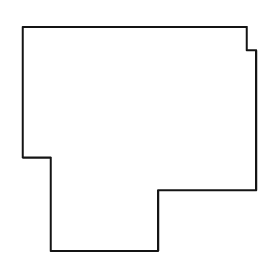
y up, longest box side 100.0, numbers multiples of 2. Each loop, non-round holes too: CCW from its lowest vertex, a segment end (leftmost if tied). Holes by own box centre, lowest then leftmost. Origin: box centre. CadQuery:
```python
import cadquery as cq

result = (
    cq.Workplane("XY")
    .moveTo(-38.0, -48.0)
    .lineTo(8.0, -48.0)
    .lineTo(8.0, -22.0)
    .lineTo(50.0, -22.0)
    .lineTo(50.0, 38.0)
    .lineTo(46.0, 38.0)
    .lineTo(46.0, 48.0)
    .lineTo(-50.0, 48.0)
    .lineTo(-50.0, -8.0)
    .lineTo(-38.0, -8.0)
    .close()
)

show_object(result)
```